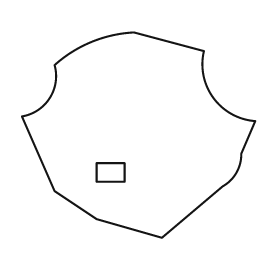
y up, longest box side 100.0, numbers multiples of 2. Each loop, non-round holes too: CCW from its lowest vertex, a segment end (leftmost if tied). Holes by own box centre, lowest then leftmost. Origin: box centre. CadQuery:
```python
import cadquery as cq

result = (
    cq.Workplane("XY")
    .moveTo(10.0, -44.0)
    .lineTo(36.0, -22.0)
    .threePointArc((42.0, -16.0), (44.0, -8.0))
    .lineTo(50.0, 6.0)
    .threePointArc((32.0, 16.0), (28.0, 36.0))
    .lineTo(-2.0, 44.0)
    .threePointArc((-20.0, 40.0), (-36.0, 30.0))
    .threePointArc((-38.0, 16.0), (-50.0, 8.0))
    .lineTo(-36.0, -24.0)
    .lineTo(-18.0, -36.0)
    .close()
    .moveTo(-18.0, -20.0)
    .lineTo(-6.0, -20.0)
    .lineTo(-6.0, -12.0)
    .lineTo(-18.0, -12.0)
    .close()
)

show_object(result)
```